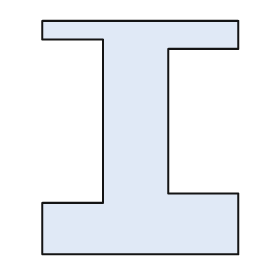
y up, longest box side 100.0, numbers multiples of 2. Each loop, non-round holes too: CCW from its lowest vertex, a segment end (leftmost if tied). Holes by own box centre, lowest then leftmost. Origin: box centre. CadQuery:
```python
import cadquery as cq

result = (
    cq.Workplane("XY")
    .moveTo(-42.0, -50.0)
    .lineTo(42.0, -50.0)
    .lineTo(42.0, -24.0)
    .lineTo(12.0, -24.0)
    .lineTo(12.0, 38.0)
    .lineTo(42.0, 38.0)
    .lineTo(42.0, 50.0)
    .lineTo(-42.0, 50.0)
    .lineTo(-42.0, 42.0)
    .lineTo(-16.0, 42.0)
    .lineTo(-16.0, -28.0)
    .lineTo(-42.0, -28.0)
    .close()
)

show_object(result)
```